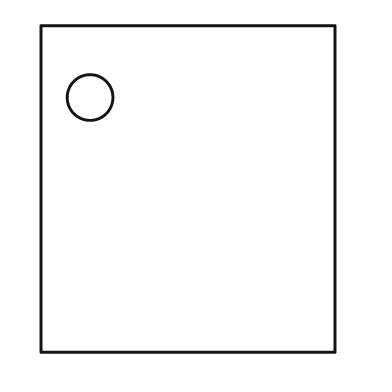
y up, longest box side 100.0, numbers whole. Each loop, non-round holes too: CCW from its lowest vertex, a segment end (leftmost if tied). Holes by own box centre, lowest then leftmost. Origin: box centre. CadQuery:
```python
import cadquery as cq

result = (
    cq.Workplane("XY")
    .moveTo(-45.0, -50.0)
    .lineTo(45.0, -50.0)
    .lineTo(45.0, 50.0)
    .lineTo(-45.0, 50.0)
    .close()
    .moveTo(-30.0, 28.0)
    .circle(7.0)
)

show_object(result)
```